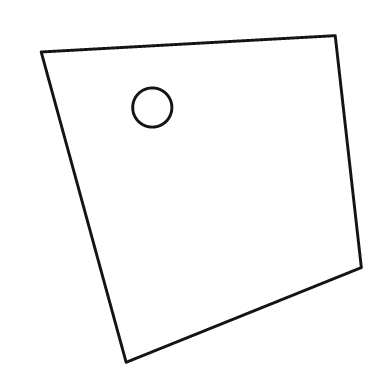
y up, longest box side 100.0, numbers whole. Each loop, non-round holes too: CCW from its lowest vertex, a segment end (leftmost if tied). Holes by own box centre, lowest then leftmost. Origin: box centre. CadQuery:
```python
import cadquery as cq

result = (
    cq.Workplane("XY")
    .moveTo(-23.0, -50.0)
    .lineTo(49.0, -21.0)
    .lineTo(41.0, 50.0)
    .lineTo(-49.0, 45.0)
    .close()
    .moveTo(-15.0, 28.0)
    .circle(6.0)
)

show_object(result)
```